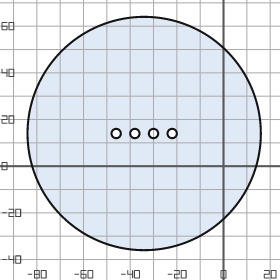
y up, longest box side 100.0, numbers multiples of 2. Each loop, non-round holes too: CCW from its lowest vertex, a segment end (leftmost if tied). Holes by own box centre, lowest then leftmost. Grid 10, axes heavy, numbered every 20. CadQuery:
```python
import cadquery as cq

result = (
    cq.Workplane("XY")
    .moveTo(-34.0, 14.0)
    .circle(50.0)
    .moveTo(-46.0, 14.0)
    .circle(2.0)
    .moveTo(-38.0, 14.0)
    .circle(2.0)
    .moveTo(-30.0, 14.0)
    .circle(2.0)
    .moveTo(-22.0, 14.0)
    .circle(2.0)
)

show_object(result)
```